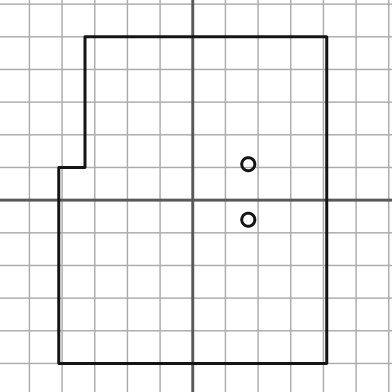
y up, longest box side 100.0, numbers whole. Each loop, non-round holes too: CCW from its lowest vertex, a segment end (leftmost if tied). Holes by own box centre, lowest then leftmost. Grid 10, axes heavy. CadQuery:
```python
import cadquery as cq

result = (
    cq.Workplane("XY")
    .moveTo(-41.0, -50.0)
    .lineTo(41.0, -50.0)
    .lineTo(41.0, 50.0)
    .lineTo(-33.0, 50.0)
    .lineTo(-33.0, 10.0)
    .lineTo(-41.0, 10.0)
    .close()
    .moveTo(17.0, -6.0)
    .circle(2.0)
    .moveTo(17.0, 11.0)
    .circle(2.0)
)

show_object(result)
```